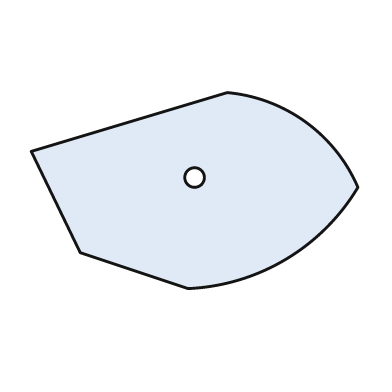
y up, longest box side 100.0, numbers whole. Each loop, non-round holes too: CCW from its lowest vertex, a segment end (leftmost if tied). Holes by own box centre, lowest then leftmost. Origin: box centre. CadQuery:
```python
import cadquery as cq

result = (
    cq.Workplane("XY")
    .moveTo(-2.0, -30.0)
    .threePointArc((28.0, -21.0), (50.0, 1.0))
    .threePointArc((34.0, 21.0), (10.0, 30.0))
    .lineTo(-50.0, 12.0)
    .lineTo(-35.0, -19.0)
    .close()
    .moveTo(0.0, 4.0)
    .circle(3.0)
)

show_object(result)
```